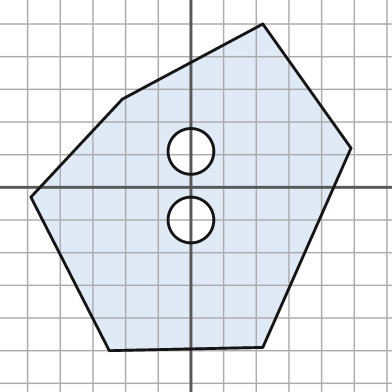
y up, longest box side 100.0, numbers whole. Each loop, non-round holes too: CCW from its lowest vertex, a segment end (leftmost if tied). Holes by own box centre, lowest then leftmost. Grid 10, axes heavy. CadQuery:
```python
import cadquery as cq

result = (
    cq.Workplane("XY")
    .moveTo(-25.0, -50.0)
    .lineTo(22.0, -49.0)
    .lineTo(49.0, 12.0)
    .lineTo(22.0, 50.0)
    .lineTo(-21.0, 27.0)
    .lineTo(-49.0, -3.0)
    .close()
    .moveTo(0.0, -10.0)
    .circle(7.0)
    .moveTo(0.0, 11.0)
    .circle(7.0)
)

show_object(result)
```